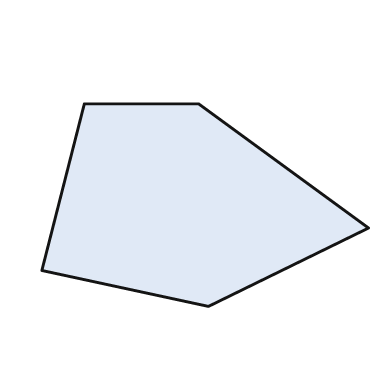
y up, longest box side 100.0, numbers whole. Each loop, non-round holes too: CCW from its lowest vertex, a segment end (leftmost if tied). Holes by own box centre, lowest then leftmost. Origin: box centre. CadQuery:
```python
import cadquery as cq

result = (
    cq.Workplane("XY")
    .moveTo(1.0, -31.0)
    .lineTo(50.0, -7.0)
    .lineTo(-2.0, 31.0)
    .lineTo(-37.0, 31.0)
    .lineTo(-50.0, -20.0)
    .close()
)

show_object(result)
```